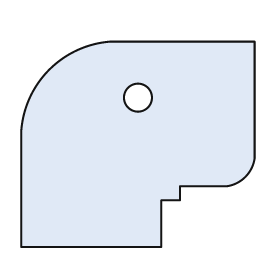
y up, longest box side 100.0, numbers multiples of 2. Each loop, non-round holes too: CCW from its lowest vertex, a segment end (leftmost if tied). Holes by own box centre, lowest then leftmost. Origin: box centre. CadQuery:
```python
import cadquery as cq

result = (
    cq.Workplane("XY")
    .moveTo(-50.0, -44.0)
    .lineTo(10.0, -44.0)
    .lineTo(10.0, -24.0)
    .lineTo(18.0, -24.0)
    .lineTo(18.0, -18.0)
    .lineTo(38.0, -18.0)
    .threePointArc((46.0, -14.0), (50.0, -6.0))
    .lineTo(50.0, 44.0)
    .lineTo(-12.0, 44.0)
    .threePointArc((-38.0, 32.0), (-50.0, 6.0))
    .close()
    .moveTo(0.0, 20.0)
    .circle(6.0)
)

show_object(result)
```